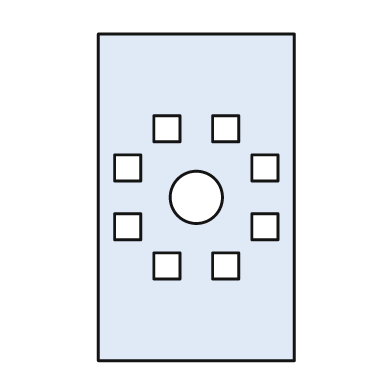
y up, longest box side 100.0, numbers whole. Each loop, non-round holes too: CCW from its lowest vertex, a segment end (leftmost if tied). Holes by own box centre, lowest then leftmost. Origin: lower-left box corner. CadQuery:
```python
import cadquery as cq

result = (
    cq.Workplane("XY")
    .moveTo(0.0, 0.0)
    .lineTo(60.0, 0.0)
    .lineTo(60.0, 100.0)
    .lineTo(0.0, 100.0)
    .close()
    .moveTo(17.0, 25.0)
    .lineTo(25.0, 25.0)
    .lineTo(25.0, 33.0)
    .lineTo(17.0, 33.0)
    .close()
    .moveTo(35.0, 25.0)
    .lineTo(43.0, 25.0)
    .lineTo(43.0, 33.0)
    .lineTo(35.0, 33.0)
    .close()
    .moveTo(5.0, 37.0)
    .lineTo(13.0, 37.0)
    .lineTo(13.0, 45.0)
    .lineTo(5.0, 45.0)
    .close()
    .moveTo(47.0, 37.0)
    .lineTo(55.0, 37.0)
    .lineTo(55.0, 45.0)
    .lineTo(47.0, 45.0)
    .close()
    .moveTo(30.0, 50.0)
    .circle(8.0)
    .moveTo(5.0, 55.0)
    .lineTo(13.0, 55.0)
    .lineTo(13.0, 63.0)
    .lineTo(5.0, 63.0)
    .close()
    .moveTo(47.0, 55.0)
    .lineTo(55.0, 55.0)
    .lineTo(55.0, 63.0)
    .lineTo(47.0, 63.0)
    .close()
    .moveTo(17.0, 67.0)
    .lineTo(25.0, 67.0)
    .lineTo(25.0, 75.0)
    .lineTo(17.0, 75.0)
    .close()
    .moveTo(35.0, 67.0)
    .lineTo(43.0, 67.0)
    .lineTo(43.0, 75.0)
    .lineTo(35.0, 75.0)
    .close()
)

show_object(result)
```